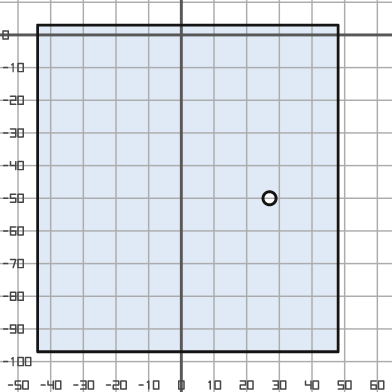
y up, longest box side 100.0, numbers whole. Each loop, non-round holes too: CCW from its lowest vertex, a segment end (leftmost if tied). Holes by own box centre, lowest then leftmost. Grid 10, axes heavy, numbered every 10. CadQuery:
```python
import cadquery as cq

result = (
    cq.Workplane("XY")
    .moveTo(-44.0, -97.0)
    .lineTo(48.0, -97.0)
    .lineTo(48.0, 3.0)
    .lineTo(-44.0, 3.0)
    .close()
    .moveTo(27.0, -50.0)
    .circle(2.0)
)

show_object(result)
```